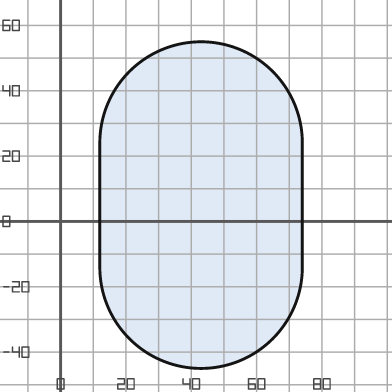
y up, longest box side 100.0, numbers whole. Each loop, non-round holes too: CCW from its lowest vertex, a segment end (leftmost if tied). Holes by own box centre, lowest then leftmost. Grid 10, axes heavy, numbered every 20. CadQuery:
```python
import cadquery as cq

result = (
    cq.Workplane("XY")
    .moveTo(12.0, -14.0)
    .threePointArc((43.0, -45.0), (74.0, -14.0))
    .lineTo(74.0, 24.0)
    .threePointArc((43.0, 55.0), (12.0, 24.0))
    .close()
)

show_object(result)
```